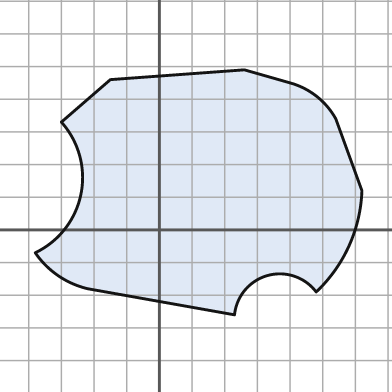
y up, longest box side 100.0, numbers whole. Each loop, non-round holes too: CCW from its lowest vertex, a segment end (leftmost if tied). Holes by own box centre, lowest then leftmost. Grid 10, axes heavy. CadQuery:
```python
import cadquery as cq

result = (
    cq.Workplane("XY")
    .moveTo(23.0, -26.0)
    .threePointArc((33.0, -14.0), (48.0, -19.0))
    .threePointArc((58.0, -5.0), (62.0, 12.0))
    .lineTo(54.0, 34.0)
    .threePointArc((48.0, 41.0), (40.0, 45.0))
    .lineTo(26.0, 49.0)
    .lineTo(-15.0, 46.0)
    .lineTo(-30.0, 33.0)
    .threePointArc((-24.0, 11.0), (-38.0, -7.0))
    .threePointArc((-31.0, -14.0), (-22.0, -18.0))
    .close()
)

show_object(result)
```